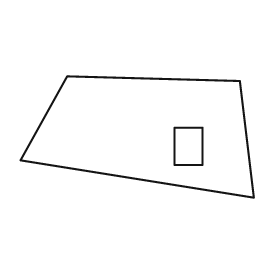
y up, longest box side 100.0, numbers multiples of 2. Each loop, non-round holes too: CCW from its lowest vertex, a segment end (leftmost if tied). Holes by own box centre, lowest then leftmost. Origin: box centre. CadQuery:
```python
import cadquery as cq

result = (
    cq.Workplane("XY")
    .moveTo(50.0, -26.0)
    .lineTo(44.0, 24.0)
    .lineTo(-30.0, 26.0)
    .lineTo(-50.0, -10.0)
    .close()
    .moveTo(16.0, -12.0)
    .lineTo(28.0, -12.0)
    .lineTo(28.0, 4.0)
    .lineTo(16.0, 4.0)
    .close()
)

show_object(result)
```